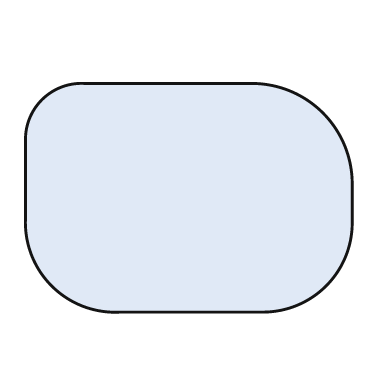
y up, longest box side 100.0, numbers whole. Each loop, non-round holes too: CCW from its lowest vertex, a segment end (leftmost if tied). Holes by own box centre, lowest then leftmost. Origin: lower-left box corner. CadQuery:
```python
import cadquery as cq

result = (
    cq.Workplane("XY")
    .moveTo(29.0, 0.0)
    .lineTo(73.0, 0.0)
    .threePointArc((92.0, 8.0), (100.0, 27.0))
    .lineTo(100.0, 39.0)
    .threePointArc((91.0, 61.0), (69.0, 70.0))
    .lineTo(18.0, 70.0)
    .threePointArc((5.0, 65.0), (0.0, 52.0))
    .lineTo(0.0, 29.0)
    .threePointArc((8.0, 8.0), (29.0, 0.0))
    .close()
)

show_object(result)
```